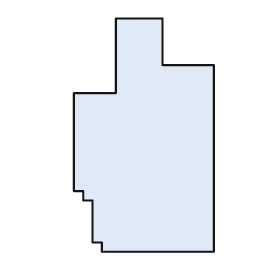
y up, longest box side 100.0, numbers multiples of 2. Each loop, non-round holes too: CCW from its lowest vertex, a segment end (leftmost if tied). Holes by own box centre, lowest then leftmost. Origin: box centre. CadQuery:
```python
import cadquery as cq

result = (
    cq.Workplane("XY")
    .moveTo(-18.0, -50.0)
    .lineTo(30.0, -50.0)
    .lineTo(30.0, 30.0)
    .lineTo(8.0, 30.0)
    .lineTo(8.0, 50.0)
    .lineTo(-12.0, 50.0)
    .lineTo(-12.0, 18.0)
    .lineTo(-30.0, 18.0)
    .lineTo(-30.0, -24.0)
    .lineTo(-26.0, -24.0)
    .lineTo(-26.0, -28.0)
    .lineTo(-22.0, -28.0)
    .lineTo(-22.0, -46.0)
    .lineTo(-18.0, -46.0)
    .close()
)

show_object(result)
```